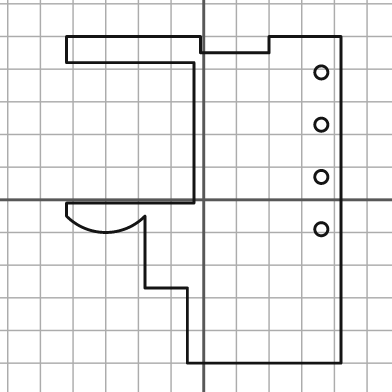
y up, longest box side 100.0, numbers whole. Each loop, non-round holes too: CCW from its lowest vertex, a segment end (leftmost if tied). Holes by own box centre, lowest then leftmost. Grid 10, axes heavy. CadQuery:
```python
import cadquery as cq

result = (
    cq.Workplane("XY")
    .moveTo(-5.0, -50.0)
    .lineTo(42.0, -50.0)
    .lineTo(42.0, 50.0)
    .lineTo(20.0, 50.0)
    .lineTo(20.0, 45.0)
    .lineTo(-1.0, 45.0)
    .lineTo(-1.0, 50.0)
    .lineTo(-42.0, 50.0)
    .lineTo(-42.0, 42.0)
    .lineTo(-3.0, 42.0)
    .lineTo(-3.0, -1.0)
    .lineTo(-42.0, -1.0)
    .lineTo(-42.0, -5.0)
    .threePointArc((-30.0, -10.0), (-18.0, -5.0))
    .lineTo(-18.0, -27.0)
    .lineTo(-5.0, -27.0)
    .close()
    .moveTo(36.0, -9.0)
    .circle(2.0)
    .moveTo(36.0, 7.0)
    .circle(2.0)
    .moveTo(36.0, 23.0)
    .circle(2.0)
    .moveTo(36.0, 39.0)
    .circle(2.0)
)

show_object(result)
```